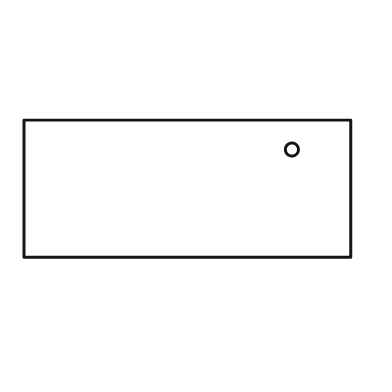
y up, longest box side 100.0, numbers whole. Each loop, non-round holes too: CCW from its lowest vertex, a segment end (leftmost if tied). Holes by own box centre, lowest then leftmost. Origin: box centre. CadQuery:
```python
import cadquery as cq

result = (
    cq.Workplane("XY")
    .moveTo(-50.0, -21.0)
    .lineTo(50.0, -21.0)
    .lineTo(50.0, 21.0)
    .lineTo(-50.0, 21.0)
    .close()
    .moveTo(32.0, 12.0)
    .circle(2.0)
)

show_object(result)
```